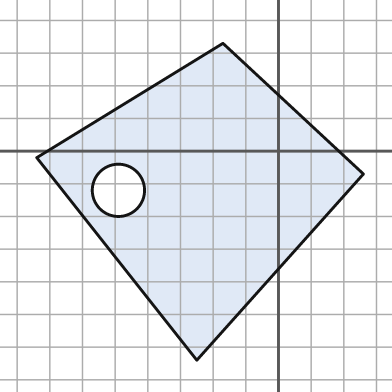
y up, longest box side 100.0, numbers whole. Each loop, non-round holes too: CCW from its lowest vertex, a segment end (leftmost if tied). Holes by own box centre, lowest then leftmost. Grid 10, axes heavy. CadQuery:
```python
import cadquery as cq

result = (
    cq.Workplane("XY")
    .moveTo(-25.0, -64.0)
    .lineTo(26.0, -7.0)
    .lineTo(-17.0, 33.0)
    .lineTo(-74.0, -2.0)
    .close()
    .moveTo(-49.0, -12.0)
    .circle(8.0)
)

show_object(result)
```